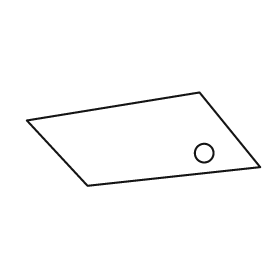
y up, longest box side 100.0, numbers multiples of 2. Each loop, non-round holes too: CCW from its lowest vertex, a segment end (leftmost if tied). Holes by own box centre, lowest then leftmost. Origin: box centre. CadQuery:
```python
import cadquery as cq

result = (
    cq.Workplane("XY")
    .moveTo(-24.0, -20.0)
    .lineTo(50.0, -12.0)
    .lineTo(24.0, 20.0)
    .lineTo(-50.0, 8.0)
    .close()
    .moveTo(26.0, -6.0)
    .circle(4.0)
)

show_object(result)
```